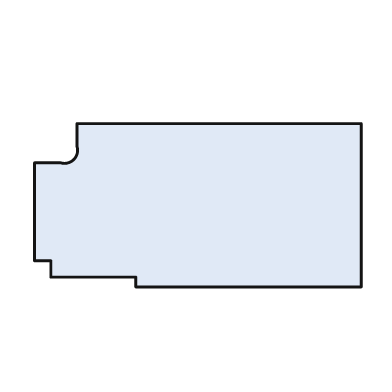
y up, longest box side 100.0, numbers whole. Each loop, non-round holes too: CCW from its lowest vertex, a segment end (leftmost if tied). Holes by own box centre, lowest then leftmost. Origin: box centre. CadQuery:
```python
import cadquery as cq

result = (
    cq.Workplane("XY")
    .moveTo(-19.0, -25.0)
    .lineTo(50.0, -25.0)
    .lineTo(50.0, 25.0)
    .lineTo(-37.0, 25.0)
    .lineTo(-37.0, 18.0)
    .threePointArc((-38.0, 14.0), (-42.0, 13.0))
    .lineTo(-50.0, 13.0)
    .lineTo(-50.0, -17.0)
    .lineTo(-45.0, -17.0)
    .lineTo(-45.0, -22.0)
    .lineTo(-19.0, -22.0)
    .close()
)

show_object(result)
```